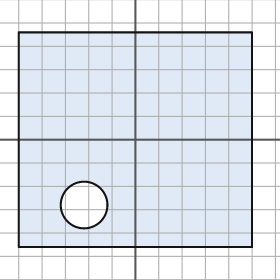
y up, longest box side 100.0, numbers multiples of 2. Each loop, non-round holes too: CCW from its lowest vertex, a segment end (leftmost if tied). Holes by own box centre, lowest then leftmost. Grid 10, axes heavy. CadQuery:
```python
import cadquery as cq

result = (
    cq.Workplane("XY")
    .moveTo(-50.0, -46.0)
    .lineTo(50.0, -46.0)
    .lineTo(50.0, 46.0)
    .lineTo(-50.0, 46.0)
    .close()
    .moveTo(-22.0, -28.0)
    .circle(10.0)
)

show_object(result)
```